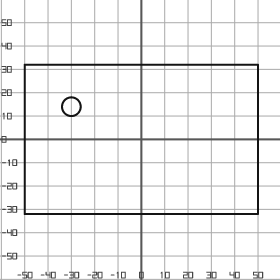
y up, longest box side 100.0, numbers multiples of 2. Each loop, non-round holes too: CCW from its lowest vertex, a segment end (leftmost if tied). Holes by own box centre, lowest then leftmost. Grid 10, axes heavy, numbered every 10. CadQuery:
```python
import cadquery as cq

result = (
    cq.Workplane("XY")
    .moveTo(-50.0, -32.0)
    .lineTo(50.0, -32.0)
    .lineTo(50.0, 32.0)
    .lineTo(-50.0, 32.0)
    .close()
    .moveTo(-30.0, 14.0)
    .circle(4.0)
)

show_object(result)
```